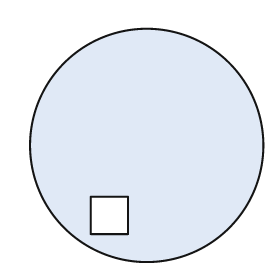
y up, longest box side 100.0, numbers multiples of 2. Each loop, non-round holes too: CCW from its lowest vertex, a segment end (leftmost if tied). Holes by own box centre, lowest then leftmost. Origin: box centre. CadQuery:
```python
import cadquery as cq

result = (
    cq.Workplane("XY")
    .moveTo(0.0, 0.0)
    .circle(50.0)
    .moveTo(-24.0, -38.0)
    .lineTo(-8.0, -38.0)
    .lineTo(-8.0, -22.0)
    .lineTo(-24.0, -22.0)
    .close()
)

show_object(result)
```